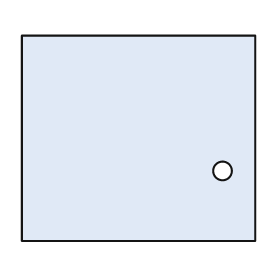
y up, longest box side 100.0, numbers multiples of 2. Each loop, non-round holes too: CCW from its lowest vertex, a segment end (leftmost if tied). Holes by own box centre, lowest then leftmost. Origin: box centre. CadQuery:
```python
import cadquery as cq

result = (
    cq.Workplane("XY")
    .moveTo(-50.0, -44.0)
    .lineTo(50.0, -44.0)
    .lineTo(50.0, 44.0)
    .lineTo(-50.0, 44.0)
    .close()
    .moveTo(36.0, -14.0)
    .circle(4.0)
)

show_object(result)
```